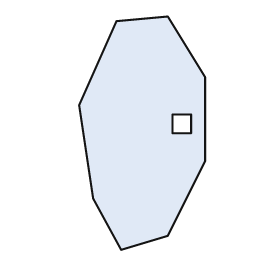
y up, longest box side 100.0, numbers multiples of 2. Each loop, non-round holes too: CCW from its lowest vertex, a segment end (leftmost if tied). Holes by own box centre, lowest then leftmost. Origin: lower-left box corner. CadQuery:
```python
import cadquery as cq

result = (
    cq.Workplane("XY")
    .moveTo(18.0, 0.0)
    .lineTo(38.0, 6.0)
    .lineTo(54.0, 38.0)
    .lineTo(54.0, 74.0)
    .lineTo(38.0, 100.0)
    .lineTo(16.0, 98.0)
    .lineTo(0.0, 62.0)
    .lineTo(6.0, 22.0)
    .close()
    .moveTo(40.0, 50.0)
    .lineTo(48.0, 50.0)
    .lineTo(48.0, 58.0)
    .lineTo(40.0, 58.0)
    .close()
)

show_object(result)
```